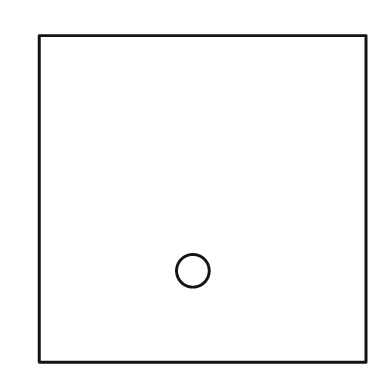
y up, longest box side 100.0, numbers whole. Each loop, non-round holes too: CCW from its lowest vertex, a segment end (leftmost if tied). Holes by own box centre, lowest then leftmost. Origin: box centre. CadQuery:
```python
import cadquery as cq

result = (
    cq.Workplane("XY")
    .moveTo(-50.0, -50.0)
    .lineTo(50.0, -50.0)
    .lineTo(50.0, 50.0)
    .lineTo(-50.0, 50.0)
    .close()
    .moveTo(-3.0, -22.0)
    .circle(5.0)
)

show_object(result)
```